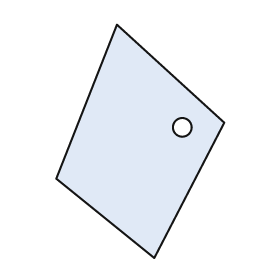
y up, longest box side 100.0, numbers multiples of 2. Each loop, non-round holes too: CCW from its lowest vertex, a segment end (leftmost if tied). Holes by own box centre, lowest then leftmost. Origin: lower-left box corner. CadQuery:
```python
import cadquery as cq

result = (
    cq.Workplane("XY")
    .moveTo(42.0, 0.0)
    .lineTo(72.0, 58.0)
    .lineTo(26.0, 100.0)
    .lineTo(0.0, 34.0)
    .close()
    .moveTo(54.0, 56.0)
    .circle(4.0)
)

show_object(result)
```